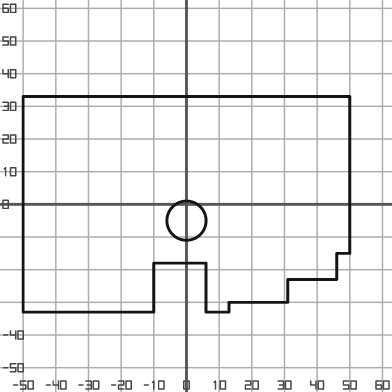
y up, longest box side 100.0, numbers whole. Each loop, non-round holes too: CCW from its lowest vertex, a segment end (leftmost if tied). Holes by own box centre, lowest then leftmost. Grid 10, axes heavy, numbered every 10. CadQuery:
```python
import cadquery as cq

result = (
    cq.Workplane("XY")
    .moveTo(-50.0, -33.0)
    .lineTo(-10.0, -33.0)
    .lineTo(-10.0, -18.0)
    .lineTo(6.0, -18.0)
    .lineTo(6.0, -33.0)
    .lineTo(13.0, -33.0)
    .lineTo(13.0, -30.0)
    .lineTo(31.0, -30.0)
    .lineTo(31.0, -23.0)
    .lineTo(46.0, -23.0)
    .lineTo(46.0, -15.0)
    .lineTo(50.0, -15.0)
    .lineTo(50.0, 33.0)
    .lineTo(-50.0, 33.0)
    .close()
    .moveTo(0.0, -5.0)
    .circle(6.0)
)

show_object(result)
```